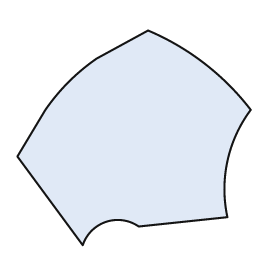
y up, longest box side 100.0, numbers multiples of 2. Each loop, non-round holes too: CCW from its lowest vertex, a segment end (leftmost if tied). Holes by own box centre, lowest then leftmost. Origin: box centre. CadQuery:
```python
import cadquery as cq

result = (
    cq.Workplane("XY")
    .moveTo(-22.0, -46.0)
    .threePointArc((-12.0, -36.0), (2.0, -38.0))
    .lineTo(40.0, -34.0)
    .threePointArc((40.0, -10.0), (50.0, 12.0))
    .threePointArc((30.0, 32.0), (6.0, 46.0))
    .lineTo(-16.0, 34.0)
    .threePointArc((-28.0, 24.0), (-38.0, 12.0))
    .lineTo(-50.0, -8.0)
    .close()
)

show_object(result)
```